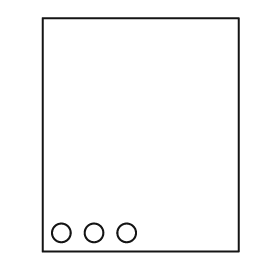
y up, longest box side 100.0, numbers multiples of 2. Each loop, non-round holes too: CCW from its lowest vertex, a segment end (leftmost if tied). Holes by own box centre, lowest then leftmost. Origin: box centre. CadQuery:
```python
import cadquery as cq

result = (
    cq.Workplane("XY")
    .moveTo(-42.0, -50.0)
    .lineTo(42.0, -50.0)
    .lineTo(42.0, 50.0)
    .lineTo(-42.0, 50.0)
    .close()
    .moveTo(-34.0, -42.0)
    .circle(4.0)
    .moveTo(-20.0, -42.0)
    .circle(4.0)
    .moveTo(-6.0, -42.0)
    .circle(4.0)
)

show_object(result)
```